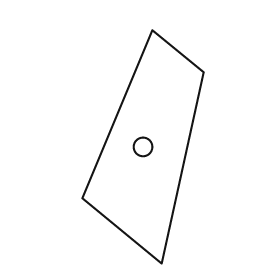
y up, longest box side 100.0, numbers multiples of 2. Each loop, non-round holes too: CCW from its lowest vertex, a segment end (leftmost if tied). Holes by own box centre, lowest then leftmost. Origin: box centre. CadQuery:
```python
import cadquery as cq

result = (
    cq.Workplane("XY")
    .moveTo(8.0, -50.0)
    .lineTo(26.0, 32.0)
    .lineTo(4.0, 50.0)
    .lineTo(-26.0, -22.0)
    .close()
    .moveTo(0.0, 0.0)
    .circle(4.0)
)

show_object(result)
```